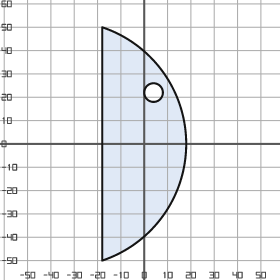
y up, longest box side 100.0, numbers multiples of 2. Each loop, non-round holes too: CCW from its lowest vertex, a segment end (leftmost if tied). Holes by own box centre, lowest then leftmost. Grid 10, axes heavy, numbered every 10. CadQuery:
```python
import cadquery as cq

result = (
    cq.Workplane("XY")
    .moveTo(-18.0, -50.0)
    .threePointArc((18.0, 0.0), (-18.0, 50.0))
    .close()
    .moveTo(4.0, 22.0)
    .circle(4.0)
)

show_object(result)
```